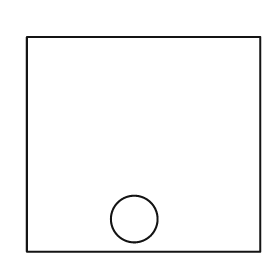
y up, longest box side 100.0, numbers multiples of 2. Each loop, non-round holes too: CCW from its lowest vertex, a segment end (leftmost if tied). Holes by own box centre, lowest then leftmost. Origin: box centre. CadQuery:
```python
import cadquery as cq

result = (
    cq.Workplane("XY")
    .moveTo(-50.0, -46.0)
    .lineTo(50.0, -46.0)
    .lineTo(50.0, 46.0)
    .lineTo(-50.0, 46.0)
    .close()
    .moveTo(-4.0, -32.0)
    .circle(10.0)
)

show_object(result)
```